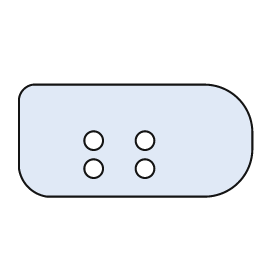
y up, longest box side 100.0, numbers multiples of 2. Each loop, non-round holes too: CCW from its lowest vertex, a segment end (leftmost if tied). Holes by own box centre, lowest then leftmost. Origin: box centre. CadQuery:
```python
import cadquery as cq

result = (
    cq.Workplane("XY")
    .moveTo(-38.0, -24.0)
    .lineTo(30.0, -24.0)
    .threePointArc((44.0, -18.0), (50.0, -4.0))
    .lineTo(50.0, 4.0)
    .threePointArc((44.0, 18.0), (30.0, 24.0))
    .lineTo(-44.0, 24.0)
    .threePointArc((-48.0, 22.0), (-50.0, 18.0))
    .lineTo(-50.0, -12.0)
    .threePointArc((-46.0, -20.0), (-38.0, -24.0))
    .close()
    .moveTo(-18.0, -12.0)
    .circle(4.0)
    .moveTo(4.0, -12.0)
    .circle(4.0)
    .moveTo(-18.0, 0.0)
    .circle(4.0)
    .moveTo(4.0, 0.0)
    .circle(4.0)
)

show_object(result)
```